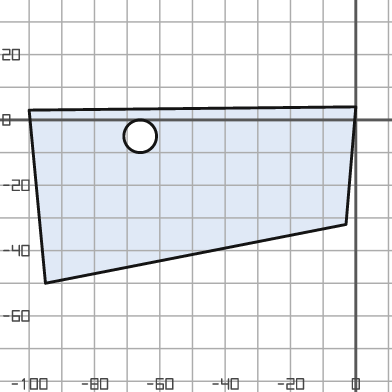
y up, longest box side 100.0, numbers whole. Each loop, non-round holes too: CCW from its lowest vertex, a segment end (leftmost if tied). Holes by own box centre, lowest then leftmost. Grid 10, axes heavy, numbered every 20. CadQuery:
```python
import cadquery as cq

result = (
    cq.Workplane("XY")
    .moveTo(-95.0, -50.0)
    .lineTo(-3.0, -32.0)
    .lineTo(0.0, 4.0)
    .lineTo(-100.0, 3.0)
    .close()
    .moveTo(-66.0, -5.0)
    .circle(5.0)
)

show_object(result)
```